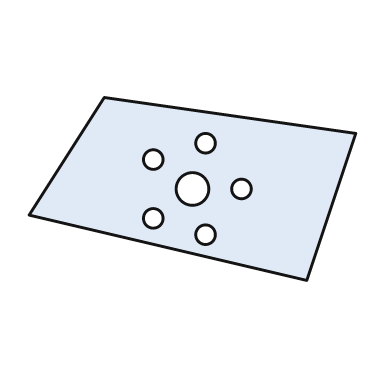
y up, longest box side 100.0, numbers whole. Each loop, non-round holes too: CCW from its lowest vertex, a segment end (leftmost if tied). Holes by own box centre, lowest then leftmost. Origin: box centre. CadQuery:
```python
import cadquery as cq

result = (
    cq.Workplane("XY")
    .moveTo(35.0, -28.0)
    .lineTo(50.0, 17.0)
    .lineTo(-27.0, 28.0)
    .lineTo(-50.0, -8.0)
    .close()
    .moveTo(4.0, -14.0)
    .circle(3.0)
    .moveTo(-12.0, -9.0)
    .circle(3.0)
    .moveTo(0.0, 0.0)
    .circle(5.0)
    .moveTo(15.0, 0.0)
    .circle(3.0)
    .moveTo(-12.0, 9.0)
    .circle(3.0)
    .moveTo(4.0, 14.0)
    .circle(3.0)
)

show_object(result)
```